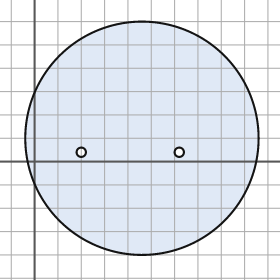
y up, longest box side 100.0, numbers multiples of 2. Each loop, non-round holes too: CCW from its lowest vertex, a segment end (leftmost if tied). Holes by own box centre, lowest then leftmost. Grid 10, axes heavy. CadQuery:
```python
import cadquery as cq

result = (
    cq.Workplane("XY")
    .moveTo(46.0, 10.0)
    .circle(50.0)
    .moveTo(20.0, 4.0)
    .circle(2.0)
    .moveTo(62.0, 4.0)
    .circle(2.0)
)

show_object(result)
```